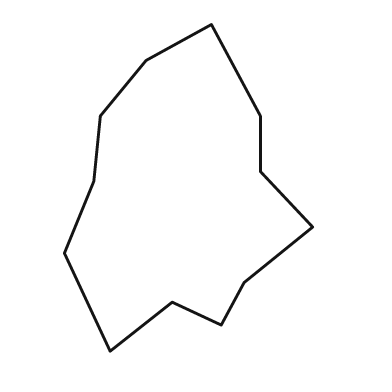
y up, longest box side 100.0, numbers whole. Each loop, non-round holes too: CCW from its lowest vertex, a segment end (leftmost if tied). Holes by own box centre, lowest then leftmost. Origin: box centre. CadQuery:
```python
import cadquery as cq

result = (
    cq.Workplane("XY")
    .moveTo(-24.0, -50.0)
    .lineTo(-5.0, -35.0)
    .lineTo(10.0, -42.0)
    .lineTo(17.0, -29.0)
    .lineTo(38.0, -12.0)
    .lineTo(22.0, 5.0)
    .lineTo(22.0, 22.0)
    .lineTo(7.0, 50.0)
    .lineTo(-13.0, 39.0)
    .lineTo(-27.0, 22.0)
    .lineTo(-29.0, 2.0)
    .lineTo(-38.0, -20.0)
    .close()
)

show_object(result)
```